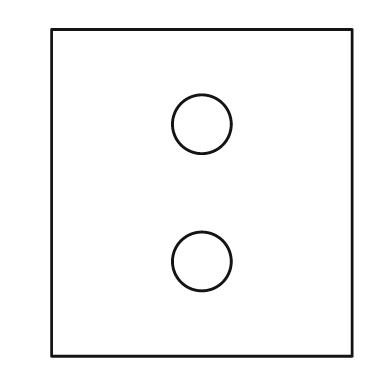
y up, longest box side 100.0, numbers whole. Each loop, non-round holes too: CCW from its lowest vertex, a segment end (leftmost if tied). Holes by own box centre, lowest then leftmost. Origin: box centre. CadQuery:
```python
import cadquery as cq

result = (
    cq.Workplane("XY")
    .moveTo(-46.0, -50.0)
    .lineTo(46.0, -50.0)
    .lineTo(46.0, 50.0)
    .lineTo(-46.0, 50.0)
    .close()
    .moveTo(0.0, -21.0)
    .circle(9.0)
    .moveTo(0.0, 21.0)
    .circle(9.0)
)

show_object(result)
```